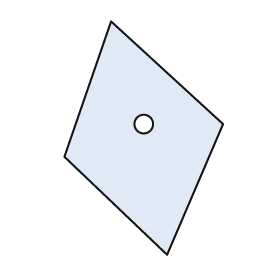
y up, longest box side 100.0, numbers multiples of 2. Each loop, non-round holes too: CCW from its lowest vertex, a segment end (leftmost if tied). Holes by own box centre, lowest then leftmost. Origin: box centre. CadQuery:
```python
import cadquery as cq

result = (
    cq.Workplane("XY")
    .moveTo(10.0, -50.0)
    .lineTo(34.0, 6.0)
    .lineTo(-14.0, 50.0)
    .lineTo(-34.0, -8.0)
    .close()
    .moveTo(0.0, 6.0)
    .circle(4.0)
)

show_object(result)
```